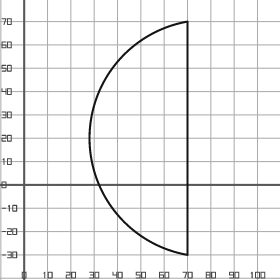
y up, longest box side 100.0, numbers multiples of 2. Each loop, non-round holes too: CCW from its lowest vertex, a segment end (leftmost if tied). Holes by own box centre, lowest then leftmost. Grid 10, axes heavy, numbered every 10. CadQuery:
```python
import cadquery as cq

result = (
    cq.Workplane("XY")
    .moveTo(70.0, -30.0)
    .lineTo(70.0, 70.0)
    .threePointArc((28.0, 20.0), (70.0, -30.0))
    .close()
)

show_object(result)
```